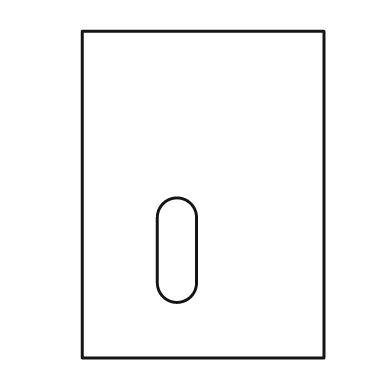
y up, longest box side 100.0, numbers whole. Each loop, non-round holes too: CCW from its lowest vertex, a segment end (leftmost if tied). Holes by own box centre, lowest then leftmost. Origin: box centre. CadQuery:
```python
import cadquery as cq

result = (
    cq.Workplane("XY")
    .moveTo(-37.0, -50.0)
    .lineTo(37.0, -50.0)
    .lineTo(37.0, 50.0)
    .lineTo(-37.0, 50.0)
    .close()
    .moveTo(-14.0, -27.0)
    .threePointArc((-8.0, -33.0), (-2.0, -27.0))
    .lineTo(-2.0, -7.0)
    .threePointArc((-8.0, -1.0), (-14.0, -7.0))
    .close()
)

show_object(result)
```